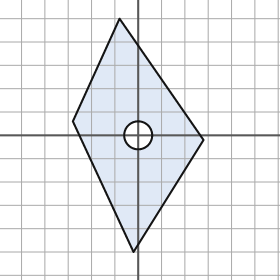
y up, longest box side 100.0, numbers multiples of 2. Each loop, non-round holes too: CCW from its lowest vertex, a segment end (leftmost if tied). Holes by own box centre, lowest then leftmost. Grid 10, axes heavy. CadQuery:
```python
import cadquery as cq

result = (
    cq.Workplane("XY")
    .moveTo(-2.0, -50.0)
    .lineTo(28.0, -2.0)
    .lineTo(-8.0, 50.0)
    .lineTo(-28.0, 6.0)
    .close()
    .moveTo(0.0, 0.0)
    .circle(6.0)
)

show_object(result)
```